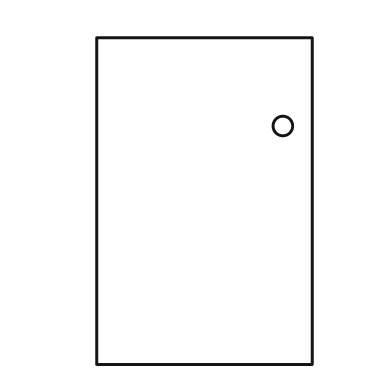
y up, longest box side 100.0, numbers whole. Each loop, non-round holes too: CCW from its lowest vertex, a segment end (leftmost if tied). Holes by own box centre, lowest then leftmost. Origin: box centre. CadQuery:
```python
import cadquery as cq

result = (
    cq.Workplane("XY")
    .moveTo(-33.0, -50.0)
    .lineTo(33.0, -50.0)
    .lineTo(33.0, 50.0)
    .lineTo(-33.0, 50.0)
    .close()
    .moveTo(24.0, 23.0)
    .circle(3.0)
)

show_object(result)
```